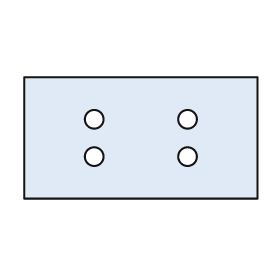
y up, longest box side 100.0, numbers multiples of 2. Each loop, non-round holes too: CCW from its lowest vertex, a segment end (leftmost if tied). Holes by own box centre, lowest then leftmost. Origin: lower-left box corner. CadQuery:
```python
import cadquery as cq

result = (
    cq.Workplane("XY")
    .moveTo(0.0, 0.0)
    .lineTo(100.0, 0.0)
    .lineTo(100.0, 52.0)
    .lineTo(0.0, 52.0)
    .close()
    .moveTo(30.0, 18.0)
    .circle(4.0)
    .moveTo(70.0, 18.0)
    .circle(4.0)
    .moveTo(30.0, 34.0)
    .circle(4.0)
    .moveTo(70.0, 34.0)
    .circle(4.0)
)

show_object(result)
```